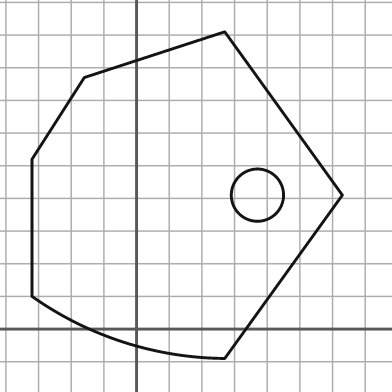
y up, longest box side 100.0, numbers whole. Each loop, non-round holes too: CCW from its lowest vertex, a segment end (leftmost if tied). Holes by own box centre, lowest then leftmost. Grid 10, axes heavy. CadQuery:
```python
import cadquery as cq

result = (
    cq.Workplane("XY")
    .moveTo(27.0, -9.0)
    .lineTo(63.0, 41.0)
    .lineTo(27.0, 91.0)
    .lineTo(-16.0, 77.0)
    .lineTo(-32.0, 52.0)
    .lineTo(-32.0, 10.0)
    .threePointArc((-4.0, -4.0), (27.0, -9.0))
    .close()
    .moveTo(37.0, 41.0)
    .circle(8.0)
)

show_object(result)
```